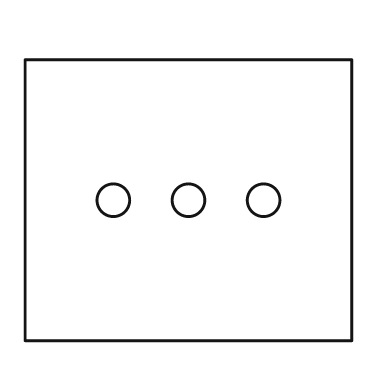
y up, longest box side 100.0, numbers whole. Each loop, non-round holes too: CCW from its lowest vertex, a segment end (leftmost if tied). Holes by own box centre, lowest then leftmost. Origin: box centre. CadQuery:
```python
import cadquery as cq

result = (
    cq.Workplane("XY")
    .moveTo(-50.0, -43.0)
    .lineTo(50.0, -43.0)
    .lineTo(50.0, 43.0)
    .lineTo(-50.0, 43.0)
    .close()
    .moveTo(-23.0, 0.0)
    .circle(5.0)
    .moveTo(0.0, 0.0)
    .circle(5.0)
    .moveTo(23.0, 0.0)
    .circle(5.0)
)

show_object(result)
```